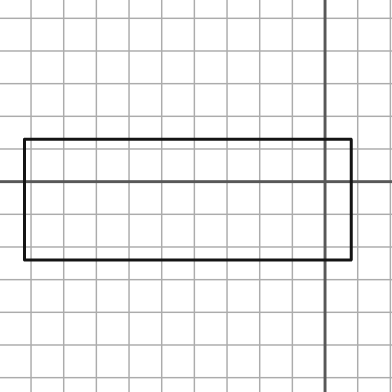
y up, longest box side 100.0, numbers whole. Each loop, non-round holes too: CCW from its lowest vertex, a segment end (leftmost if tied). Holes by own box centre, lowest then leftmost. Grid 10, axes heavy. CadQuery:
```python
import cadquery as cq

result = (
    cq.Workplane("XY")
    .moveTo(-92.0, -24.0)
    .lineTo(8.0, -24.0)
    .lineTo(8.0, 13.0)
    .lineTo(-92.0, 13.0)
    .close()
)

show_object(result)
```